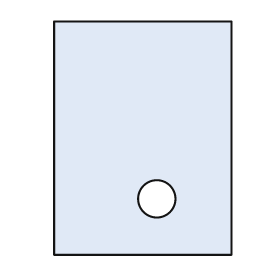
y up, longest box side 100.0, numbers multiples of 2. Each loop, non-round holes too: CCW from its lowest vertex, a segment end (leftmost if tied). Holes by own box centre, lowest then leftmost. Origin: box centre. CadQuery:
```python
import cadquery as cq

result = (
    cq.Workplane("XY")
    .moveTo(-38.0, -50.0)
    .lineTo(38.0, -50.0)
    .lineTo(38.0, 50.0)
    .lineTo(-38.0, 50.0)
    .close()
    .moveTo(6.0, -26.0)
    .circle(8.0)
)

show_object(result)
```